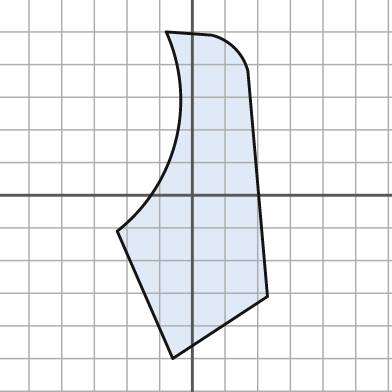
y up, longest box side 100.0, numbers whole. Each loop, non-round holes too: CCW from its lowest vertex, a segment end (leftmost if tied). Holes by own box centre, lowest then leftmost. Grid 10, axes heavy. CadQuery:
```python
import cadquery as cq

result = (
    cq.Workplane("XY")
    .moveTo(-6.0, -50.0)
    .lineTo(23.0, -31.0)
    .lineTo(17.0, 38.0)
    .threePointArc((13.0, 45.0), (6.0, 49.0))
    .lineTo(-8.0, 50.0)
    .threePointArc((-5.0, 17.0), (-23.0, -11.0))
    .close()
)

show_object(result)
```